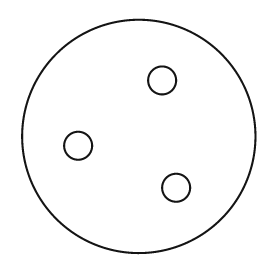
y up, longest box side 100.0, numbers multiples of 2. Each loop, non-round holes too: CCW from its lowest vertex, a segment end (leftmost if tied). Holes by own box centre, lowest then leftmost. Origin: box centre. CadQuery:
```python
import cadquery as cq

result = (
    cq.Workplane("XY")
    .moveTo(0.0, 0.0)
    .circle(50.0)
    .moveTo(16.0, -22.0)
    .circle(6.0)
    .moveTo(-26.0, -4.0)
    .circle(6.0)
    .moveTo(10.0, 24.0)
    .circle(6.0)
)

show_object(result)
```